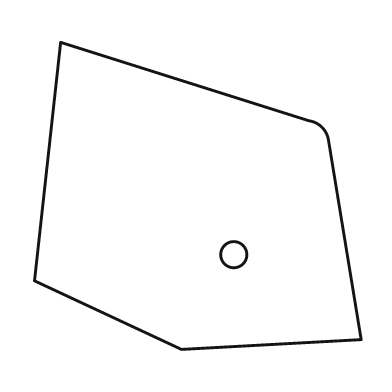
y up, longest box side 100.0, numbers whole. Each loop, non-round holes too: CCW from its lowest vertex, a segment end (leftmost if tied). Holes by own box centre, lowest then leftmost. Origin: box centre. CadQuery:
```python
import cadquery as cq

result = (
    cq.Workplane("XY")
    .moveTo(-5.0, -47.0)
    .lineTo(50.0, -44.0)
    .lineTo(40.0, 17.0)
    .threePointArc((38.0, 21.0), (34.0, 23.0))
    .lineTo(-42.0, 47.0)
    .lineTo(-50.0, -26.0)
    .close()
    .moveTo(11.0, -18.0)
    .circle(4.0)
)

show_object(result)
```